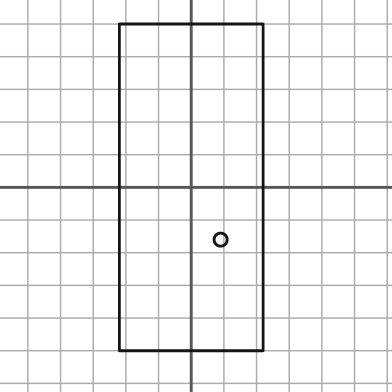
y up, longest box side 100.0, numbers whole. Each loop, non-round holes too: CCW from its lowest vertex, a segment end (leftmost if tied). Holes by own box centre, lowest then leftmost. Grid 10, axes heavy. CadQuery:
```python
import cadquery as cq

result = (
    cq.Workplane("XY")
    .moveTo(-22.0, -50.0)
    .lineTo(22.0, -50.0)
    .lineTo(22.0, 50.0)
    .lineTo(-22.0, 50.0)
    .close()
    .moveTo(9.0, -16.0)
    .circle(2.0)
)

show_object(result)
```